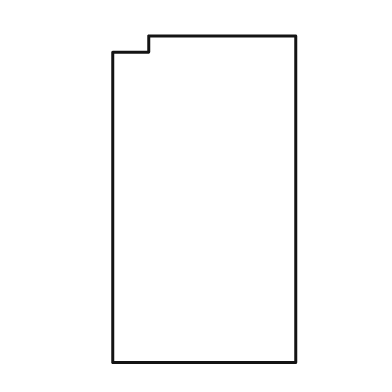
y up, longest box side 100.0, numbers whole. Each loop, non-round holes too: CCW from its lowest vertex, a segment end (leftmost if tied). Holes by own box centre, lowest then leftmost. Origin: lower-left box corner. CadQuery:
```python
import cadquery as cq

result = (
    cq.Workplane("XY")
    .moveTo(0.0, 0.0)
    .lineTo(56.0, 0.0)
    .lineTo(56.0, 100.0)
    .lineTo(11.0, 100.0)
    .lineTo(11.0, 95.0)
    .lineTo(0.0, 95.0)
    .close()
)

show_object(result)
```